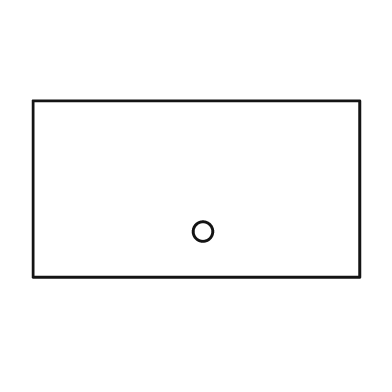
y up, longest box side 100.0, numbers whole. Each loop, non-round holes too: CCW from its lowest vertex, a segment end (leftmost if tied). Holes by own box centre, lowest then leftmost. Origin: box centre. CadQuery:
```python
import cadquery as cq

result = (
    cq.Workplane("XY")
    .moveTo(-50.0, -27.0)
    .lineTo(50.0, -27.0)
    .lineTo(50.0, 27.0)
    .lineTo(-50.0, 27.0)
    .close()
    .moveTo(2.0, -13.0)
    .circle(3.0)
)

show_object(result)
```